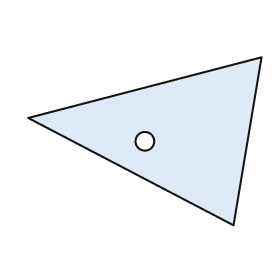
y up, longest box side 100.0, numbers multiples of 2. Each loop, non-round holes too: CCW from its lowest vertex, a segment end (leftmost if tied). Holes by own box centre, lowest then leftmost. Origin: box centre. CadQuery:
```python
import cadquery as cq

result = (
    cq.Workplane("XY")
    .moveTo(38.0, -36.0)
    .lineTo(50.0, 36.0)
    .lineTo(-50.0, 10.0)
    .close()
    .moveTo(0.0, 0.0)
    .circle(4.0)
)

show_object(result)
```